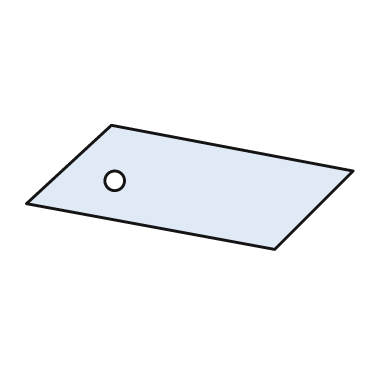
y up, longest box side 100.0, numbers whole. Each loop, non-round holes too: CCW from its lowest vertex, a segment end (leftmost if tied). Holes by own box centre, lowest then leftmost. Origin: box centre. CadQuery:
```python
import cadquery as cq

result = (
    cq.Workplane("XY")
    .moveTo(26.0, -19.0)
    .lineTo(50.0, 5.0)
    .lineTo(-24.0, 19.0)
    .lineTo(-50.0, -5.0)
    .close()
    .moveTo(-23.0, 2.0)
    .circle(3.0)
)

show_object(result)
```